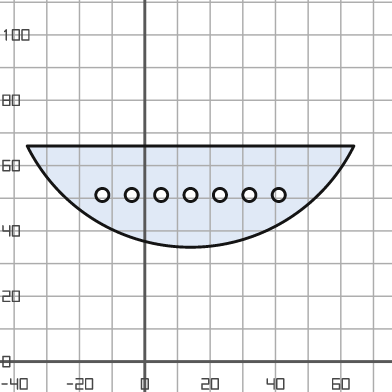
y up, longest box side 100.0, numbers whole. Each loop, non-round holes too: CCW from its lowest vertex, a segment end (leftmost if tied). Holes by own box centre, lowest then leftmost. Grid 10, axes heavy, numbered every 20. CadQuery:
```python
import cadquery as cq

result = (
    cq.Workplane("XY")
    .moveTo(-36.0, 66.0)
    .threePointArc((14.0, 35.0), (64.0, 66.0))
    .close()
    .moveTo(-13.0, 51.0)
    .circle(2.0)
    .moveTo(-4.0, 51.0)
    .circle(2.0)
    .moveTo(5.0, 51.0)
    .circle(2.0)
    .moveTo(14.0, 51.0)
    .circle(2.0)
    .moveTo(23.0, 51.0)
    .circle(2.0)
    .moveTo(32.0, 51.0)
    .circle(2.0)
    .moveTo(41.0, 51.0)
    .circle(2.0)
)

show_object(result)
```